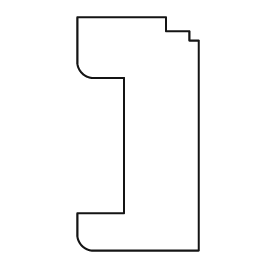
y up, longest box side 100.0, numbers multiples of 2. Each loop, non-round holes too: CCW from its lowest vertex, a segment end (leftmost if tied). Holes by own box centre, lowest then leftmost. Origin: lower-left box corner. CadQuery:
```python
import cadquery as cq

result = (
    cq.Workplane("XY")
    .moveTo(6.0, 0.0)
    .lineTo(52.0, 0.0)
    .lineTo(52.0, 90.0)
    .lineTo(48.0, 90.0)
    .lineTo(48.0, 94.0)
    .lineTo(38.0, 94.0)
    .lineTo(38.0, 100.0)
    .lineTo(0.0, 100.0)
    .lineTo(0.0, 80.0)
    .threePointArc((2.0, 76.0), (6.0, 74.0))
    .lineTo(20.0, 74.0)
    .lineTo(20.0, 16.0)
    .lineTo(0.0, 16.0)
    .lineTo(0.0, 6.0)
    .threePointArc((2.0, 2.0), (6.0, 0.0))
    .close()
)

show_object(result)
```